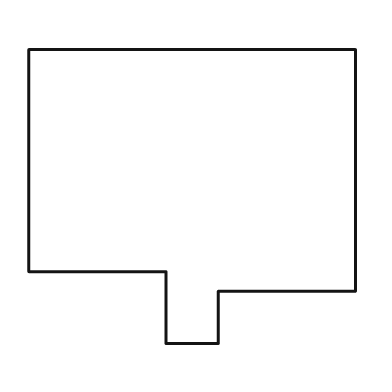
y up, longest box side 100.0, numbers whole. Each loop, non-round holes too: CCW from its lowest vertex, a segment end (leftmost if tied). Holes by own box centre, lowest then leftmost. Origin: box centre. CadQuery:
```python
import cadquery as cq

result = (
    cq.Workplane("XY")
    .moveTo(-8.0, -45.0)
    .lineTo(8.0, -45.0)
    .lineTo(8.0, -29.0)
    .lineTo(50.0, -29.0)
    .lineTo(50.0, 45.0)
    .lineTo(-50.0, 45.0)
    .lineTo(-50.0, -23.0)
    .lineTo(-8.0, -23.0)
    .close()
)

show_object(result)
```